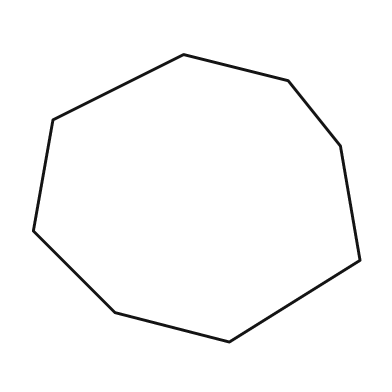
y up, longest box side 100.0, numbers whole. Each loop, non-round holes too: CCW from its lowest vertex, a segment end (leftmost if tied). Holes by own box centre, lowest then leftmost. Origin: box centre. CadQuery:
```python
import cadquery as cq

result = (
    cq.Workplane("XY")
    .moveTo(10.0, -44.0)
    .lineTo(50.0, -19.0)
    .lineTo(44.0, 16.0)
    .lineTo(28.0, 36.0)
    .lineTo(-4.0, 44.0)
    .lineTo(-44.0, 24.0)
    .lineTo(-50.0, -10.0)
    .lineTo(-25.0, -35.0)
    .close()
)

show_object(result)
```